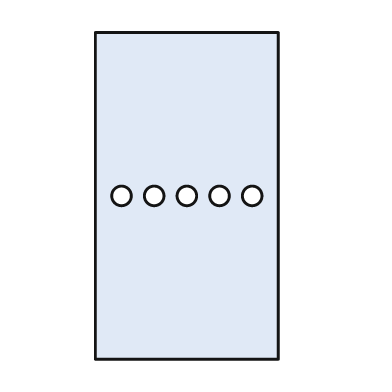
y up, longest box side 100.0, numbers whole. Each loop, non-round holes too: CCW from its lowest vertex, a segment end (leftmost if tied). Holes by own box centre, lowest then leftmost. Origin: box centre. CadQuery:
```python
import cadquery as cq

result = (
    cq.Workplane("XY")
    .moveTo(-28.0, -50.0)
    .lineTo(28.0, -50.0)
    .lineTo(28.0, 50.0)
    .lineTo(-28.0, 50.0)
    .close()
    .moveTo(-20.0, 0.0)
    .circle(3.0)
    .moveTo(-10.0, 0.0)
    .circle(3.0)
    .moveTo(0.0, 0.0)
    .circle(3.0)
    .moveTo(10.0, 0.0)
    .circle(3.0)
    .moveTo(20.0, 0.0)
    .circle(3.0)
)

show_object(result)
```